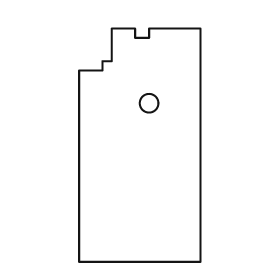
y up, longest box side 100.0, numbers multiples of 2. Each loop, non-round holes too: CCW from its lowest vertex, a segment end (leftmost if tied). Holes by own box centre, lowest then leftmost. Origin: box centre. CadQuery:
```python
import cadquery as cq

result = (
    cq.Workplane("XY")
    .moveTo(-26.0, -50.0)
    .lineTo(26.0, -50.0)
    .lineTo(26.0, 50.0)
    .lineTo(4.0, 50.0)
    .lineTo(4.0, 46.0)
    .lineTo(-2.0, 46.0)
    .lineTo(-2.0, 50.0)
    .lineTo(-12.0, 50.0)
    .lineTo(-12.0, 36.0)
    .lineTo(-16.0, 36.0)
    .lineTo(-16.0, 32.0)
    .lineTo(-26.0, 32.0)
    .close()
    .moveTo(4.0, 18.0)
    .circle(4.0)
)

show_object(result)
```